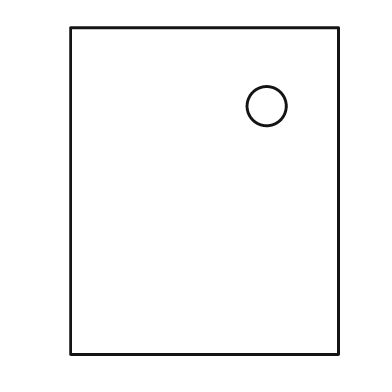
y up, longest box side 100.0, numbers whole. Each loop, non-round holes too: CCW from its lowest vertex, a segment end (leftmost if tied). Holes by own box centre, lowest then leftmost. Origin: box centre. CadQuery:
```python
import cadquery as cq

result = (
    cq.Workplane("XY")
    .moveTo(-41.0, -50.0)
    .lineTo(41.0, -50.0)
    .lineTo(41.0, 50.0)
    .lineTo(-41.0, 50.0)
    .close()
    .moveTo(19.0, 26.0)
    .circle(6.0)
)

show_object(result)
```